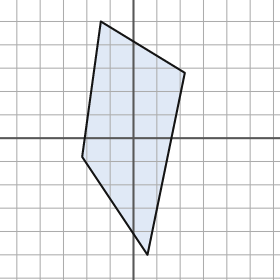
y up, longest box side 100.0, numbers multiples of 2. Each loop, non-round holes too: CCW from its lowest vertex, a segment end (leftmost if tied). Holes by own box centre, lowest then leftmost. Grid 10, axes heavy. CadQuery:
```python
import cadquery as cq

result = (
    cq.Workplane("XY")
    .moveTo(6.0, -50.0)
    .lineTo(22.0, 28.0)
    .lineTo(-14.0, 50.0)
    .lineTo(-22.0, -8.0)
    .close()
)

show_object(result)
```